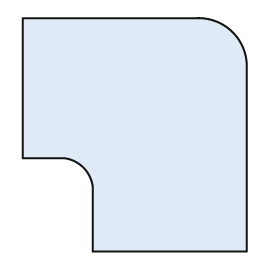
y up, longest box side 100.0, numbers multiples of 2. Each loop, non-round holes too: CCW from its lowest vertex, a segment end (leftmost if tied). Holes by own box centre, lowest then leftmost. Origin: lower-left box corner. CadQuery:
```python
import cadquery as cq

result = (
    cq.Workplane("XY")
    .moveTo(30.0, 0.0)
    .lineTo(96.0, 0.0)
    .lineTo(96.0, 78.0)
    .threePointArc((90.0, 94.0), (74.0, 100.0))
    .lineTo(0.0, 100.0)
    .lineTo(0.0, 40.0)
    .lineTo(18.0, 40.0)
    .threePointArc((26.0, 36.0), (30.0, 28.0))
    .close()
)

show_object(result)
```